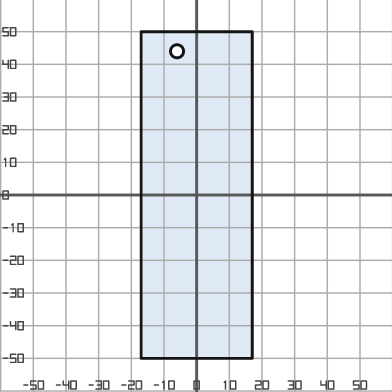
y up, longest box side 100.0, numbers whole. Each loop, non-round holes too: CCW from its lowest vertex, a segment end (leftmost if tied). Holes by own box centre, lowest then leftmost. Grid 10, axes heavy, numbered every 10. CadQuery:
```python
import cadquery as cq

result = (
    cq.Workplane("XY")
    .moveTo(-17.0, -50.0)
    .lineTo(17.0, -50.0)
    .lineTo(17.0, 50.0)
    .lineTo(-17.0, 50.0)
    .close()
    .moveTo(-6.0, 44.0)
    .circle(2.0)
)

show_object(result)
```